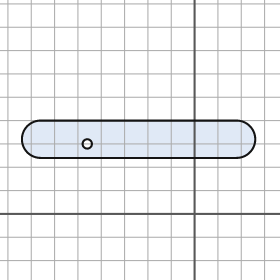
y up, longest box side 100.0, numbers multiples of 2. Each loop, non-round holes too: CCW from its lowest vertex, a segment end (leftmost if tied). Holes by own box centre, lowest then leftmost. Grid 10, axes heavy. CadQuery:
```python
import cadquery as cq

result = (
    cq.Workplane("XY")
    .moveTo(-66.0, 24.0)
    .lineTo(18.0, 24.0)
    .threePointArc((26.0, 32.0), (18.0, 40.0))
    .lineTo(-66.0, 40.0)
    .threePointArc((-74.0, 32.0), (-66.0, 24.0))
    .close()
    .moveTo(-46.0, 30.0)
    .circle(2.0)
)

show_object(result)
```